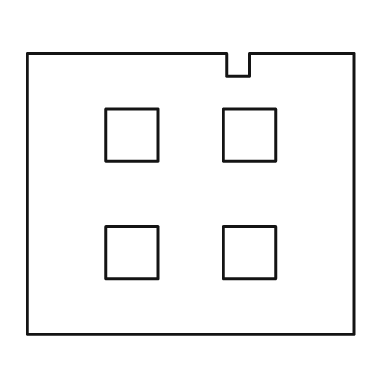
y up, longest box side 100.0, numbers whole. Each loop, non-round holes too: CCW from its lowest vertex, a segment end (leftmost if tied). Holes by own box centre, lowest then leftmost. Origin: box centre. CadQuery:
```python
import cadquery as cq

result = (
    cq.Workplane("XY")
    .moveTo(-50.0, -43.0)
    .lineTo(50.0, -43.0)
    .lineTo(50.0, 43.0)
    .lineTo(18.0, 43.0)
    .lineTo(18.0, 36.0)
    .lineTo(11.0, 36.0)
    .lineTo(11.0, 43.0)
    .lineTo(-50.0, 43.0)
    .close()
    .moveTo(-26.0, -26.0)
    .lineTo(-10.0, -26.0)
    .lineTo(-10.0, -10.0)
    .lineTo(-26.0, -10.0)
    .close()
    .moveTo(10.0, -26.0)
    .lineTo(26.0, -26.0)
    .lineTo(26.0, -10.0)
    .lineTo(10.0, -10.0)
    .close()
    .moveTo(-26.0, 10.0)
    .lineTo(-10.0, 10.0)
    .lineTo(-10.0, 26.0)
    .lineTo(-26.0, 26.0)
    .close()
    .moveTo(10.0, 10.0)
    .lineTo(26.0, 10.0)
    .lineTo(26.0, 26.0)
    .lineTo(10.0, 26.0)
    .close()
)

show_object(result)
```